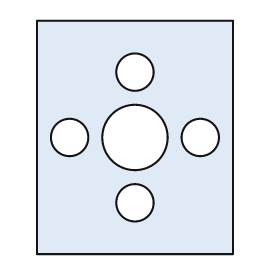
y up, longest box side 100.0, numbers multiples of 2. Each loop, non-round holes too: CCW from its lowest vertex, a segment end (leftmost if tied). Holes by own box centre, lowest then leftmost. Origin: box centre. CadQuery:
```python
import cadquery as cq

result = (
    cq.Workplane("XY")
    .moveTo(-42.0, -50.0)
    .lineTo(42.0, -50.0)
    .lineTo(42.0, 50.0)
    .lineTo(-42.0, 50.0)
    .close()
    .moveTo(0.0, -28.0)
    .circle(8.0)
    .moveTo(-28.0, 0.0)
    .circle(8.0)
    .moveTo(0.0, 0.0)
    .circle(14.0)
    .moveTo(28.0, 0.0)
    .circle(8.0)
    .moveTo(0.0, 28.0)
    .circle(8.0)
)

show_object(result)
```